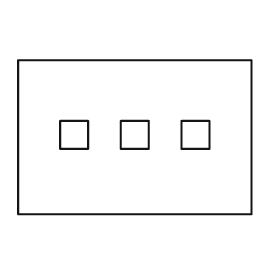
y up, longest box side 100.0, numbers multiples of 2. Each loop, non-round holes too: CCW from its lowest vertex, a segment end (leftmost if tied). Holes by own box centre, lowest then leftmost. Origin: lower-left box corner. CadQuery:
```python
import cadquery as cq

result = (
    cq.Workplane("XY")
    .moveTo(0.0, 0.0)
    .lineTo(100.0, 0.0)
    .lineTo(100.0, 66.0)
    .lineTo(0.0, 66.0)
    .close()
    .moveTo(18.0, 28.0)
    .lineTo(30.0, 28.0)
    .lineTo(30.0, 40.0)
    .lineTo(18.0, 40.0)
    .close()
    .moveTo(44.0, 28.0)
    .lineTo(56.0, 28.0)
    .lineTo(56.0, 40.0)
    .lineTo(44.0, 40.0)
    .close()
    .moveTo(70.0, 28.0)
    .lineTo(82.0, 28.0)
    .lineTo(82.0, 40.0)
    .lineTo(70.0, 40.0)
    .close()
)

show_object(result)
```